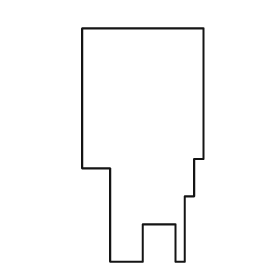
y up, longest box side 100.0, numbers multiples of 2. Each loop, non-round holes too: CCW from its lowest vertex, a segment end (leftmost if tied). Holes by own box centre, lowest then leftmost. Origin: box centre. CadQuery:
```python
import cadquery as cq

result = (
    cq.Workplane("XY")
    .moveTo(-14.0, -50.0)
    .lineTo(0.0, -50.0)
    .lineTo(0.0, -34.0)
    .lineTo(14.0, -34.0)
    .lineTo(14.0, -50.0)
    .lineTo(18.0, -50.0)
    .lineTo(18.0, -22.0)
    .lineTo(22.0, -22.0)
    .lineTo(22.0, -6.0)
    .lineTo(26.0, -6.0)
    .lineTo(26.0, 50.0)
    .lineTo(-26.0, 50.0)
    .lineTo(-26.0, -10.0)
    .lineTo(-14.0, -10.0)
    .close()
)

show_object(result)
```